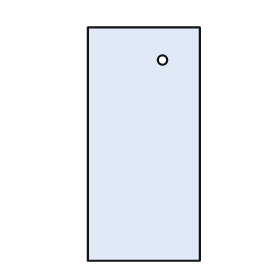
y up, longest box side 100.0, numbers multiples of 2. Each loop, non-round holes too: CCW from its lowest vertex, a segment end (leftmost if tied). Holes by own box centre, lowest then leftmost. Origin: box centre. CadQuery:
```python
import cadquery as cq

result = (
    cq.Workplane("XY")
    .moveTo(-24.0, -50.0)
    .lineTo(24.0, -50.0)
    .lineTo(24.0, 50.0)
    .lineTo(-24.0, 50.0)
    .close()
    .moveTo(8.0, 36.0)
    .circle(2.0)
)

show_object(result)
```